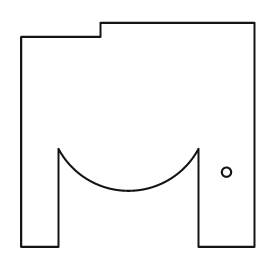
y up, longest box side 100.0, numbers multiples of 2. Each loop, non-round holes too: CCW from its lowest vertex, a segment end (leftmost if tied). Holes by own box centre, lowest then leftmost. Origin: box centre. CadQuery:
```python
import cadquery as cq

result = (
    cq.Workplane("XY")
    .moveTo(-50.0, -48.0)
    .lineTo(-34.0, -48.0)
    .lineTo(-34.0, -6.0)
    .threePointArc((-4.0, -24.0), (26.0, -6.0))
    .lineTo(26.0, -48.0)
    .lineTo(50.0, -48.0)
    .lineTo(50.0, 48.0)
    .lineTo(-16.0, 48.0)
    .lineTo(-16.0, 42.0)
    .lineTo(-50.0, 42.0)
    .close()
    .moveTo(38.0, -16.0)
    .circle(2.0)
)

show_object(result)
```